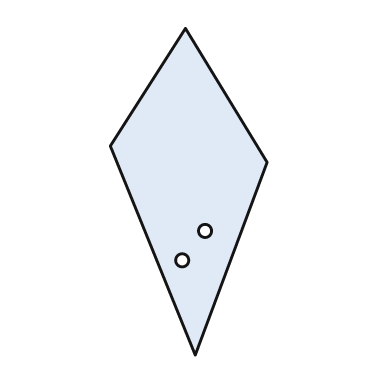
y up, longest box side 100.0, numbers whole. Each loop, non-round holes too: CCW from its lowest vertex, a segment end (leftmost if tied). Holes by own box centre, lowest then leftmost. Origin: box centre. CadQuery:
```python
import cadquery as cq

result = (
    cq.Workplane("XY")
    .moveTo(2.0, -50.0)
    .lineTo(24.0, 9.0)
    .lineTo(-1.0, 50.0)
    .lineTo(-24.0, 14.0)
    .close()
    .moveTo(-2.0, -21.0)
    .circle(2.0)
    .moveTo(5.0, -12.0)
    .circle(2.0)
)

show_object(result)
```